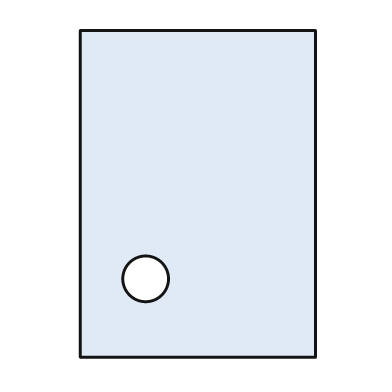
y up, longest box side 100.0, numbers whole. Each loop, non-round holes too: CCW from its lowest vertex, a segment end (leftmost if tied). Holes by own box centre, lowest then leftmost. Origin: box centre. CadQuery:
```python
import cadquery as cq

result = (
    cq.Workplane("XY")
    .moveTo(-36.0, -50.0)
    .lineTo(36.0, -50.0)
    .lineTo(36.0, 50.0)
    .lineTo(-36.0, 50.0)
    .close()
    .moveTo(-16.0, -26.0)
    .circle(7.0)
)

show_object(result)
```